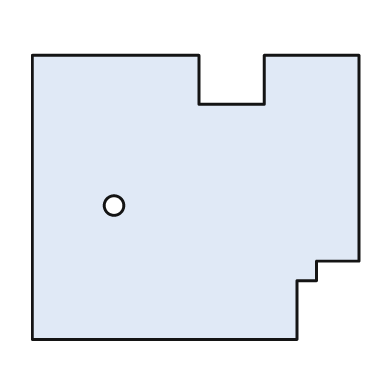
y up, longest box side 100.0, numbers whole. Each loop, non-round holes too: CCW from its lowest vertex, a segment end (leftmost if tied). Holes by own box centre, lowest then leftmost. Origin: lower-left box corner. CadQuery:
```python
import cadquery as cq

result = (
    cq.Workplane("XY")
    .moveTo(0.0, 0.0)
    .lineTo(81.0, 0.0)
    .lineTo(81.0, 18.0)
    .lineTo(87.0, 18.0)
    .lineTo(87.0, 24.0)
    .lineTo(100.0, 24.0)
    .lineTo(100.0, 87.0)
    .lineTo(71.0, 87.0)
    .lineTo(71.0, 72.0)
    .lineTo(51.0, 72.0)
    .lineTo(51.0, 87.0)
    .lineTo(0.0, 87.0)
    .close()
    .moveTo(25.0, 41.0)
    .circle(3.0)
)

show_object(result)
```